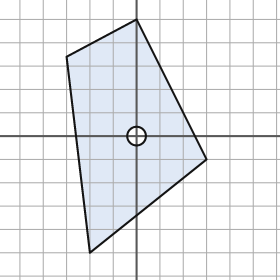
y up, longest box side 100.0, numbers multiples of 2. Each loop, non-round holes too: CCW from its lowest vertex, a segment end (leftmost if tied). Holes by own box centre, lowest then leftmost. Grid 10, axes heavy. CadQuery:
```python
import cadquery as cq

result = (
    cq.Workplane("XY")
    .moveTo(-20.0, -50.0)
    .lineTo(30.0, -10.0)
    .lineTo(0.0, 50.0)
    .lineTo(-30.0, 34.0)
    .close()
    .moveTo(0.0, 0.0)
    .circle(4.0)
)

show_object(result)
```